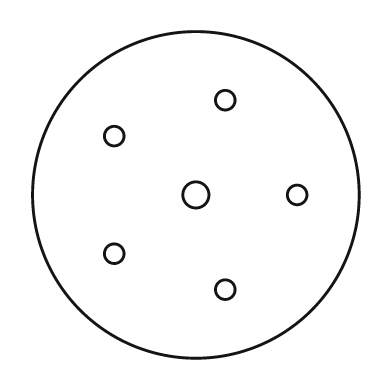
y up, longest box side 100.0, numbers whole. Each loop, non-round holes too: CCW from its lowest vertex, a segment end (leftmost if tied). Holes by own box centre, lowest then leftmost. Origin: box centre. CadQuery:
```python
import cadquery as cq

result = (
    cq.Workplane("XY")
    .moveTo(0.0, 0.0)
    .circle(50.0)
    .moveTo(9.0, -29.0)
    .circle(3.0)
    .moveTo(-25.0, -18.0)
    .circle(3.0)
    .moveTo(0.0, 0.0)
    .circle(4.0)
    .moveTo(31.0, 0.0)
    .circle(3.0)
    .moveTo(-25.0, 18.0)
    .circle(3.0)
    .moveTo(9.0, 29.0)
    .circle(3.0)
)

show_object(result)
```